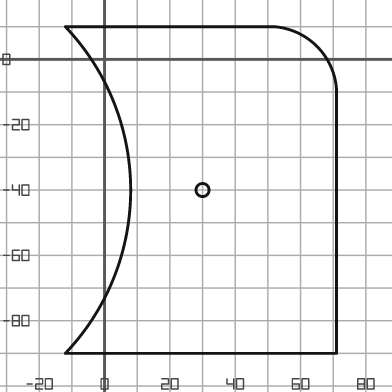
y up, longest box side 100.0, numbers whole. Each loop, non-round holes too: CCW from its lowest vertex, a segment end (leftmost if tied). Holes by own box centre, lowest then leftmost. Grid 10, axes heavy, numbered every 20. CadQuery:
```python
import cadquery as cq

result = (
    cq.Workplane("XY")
    .moveTo(-12.0, -90.0)
    .lineTo(71.0, -90.0)
    .lineTo(71.0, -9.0)
    .threePointArc((65.0, 4.0), (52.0, 10.0))
    .lineTo(-12.0, 10.0)
    .threePointArc((8.0, -40.0), (-12.0, -90.0))
    .close()
    .moveTo(30.0, -40.0)
    .circle(2.0)
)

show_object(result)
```